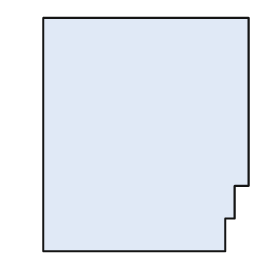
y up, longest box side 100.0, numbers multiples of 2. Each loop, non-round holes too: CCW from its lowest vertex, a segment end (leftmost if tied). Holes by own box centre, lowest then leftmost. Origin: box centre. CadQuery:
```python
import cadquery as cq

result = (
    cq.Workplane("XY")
    .moveTo(-44.0, -50.0)
    .lineTo(34.0, -50.0)
    .lineTo(34.0, -36.0)
    .lineTo(38.0, -36.0)
    .lineTo(38.0, -22.0)
    .lineTo(44.0, -22.0)
    .lineTo(44.0, 50.0)
    .lineTo(-44.0, 50.0)
    .close()
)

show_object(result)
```